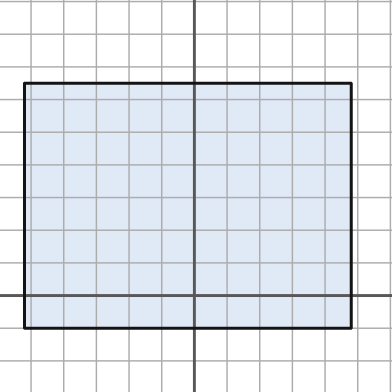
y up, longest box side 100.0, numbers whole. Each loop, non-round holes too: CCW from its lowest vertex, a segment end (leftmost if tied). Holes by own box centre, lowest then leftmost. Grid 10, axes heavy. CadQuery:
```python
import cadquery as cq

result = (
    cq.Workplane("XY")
    .moveTo(-52.0, -10.0)
    .lineTo(48.0, -10.0)
    .lineTo(48.0, 65.0)
    .lineTo(-52.0, 65.0)
    .close()
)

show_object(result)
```